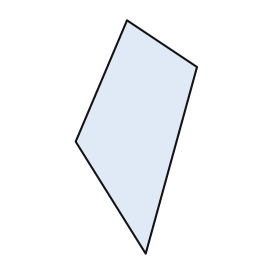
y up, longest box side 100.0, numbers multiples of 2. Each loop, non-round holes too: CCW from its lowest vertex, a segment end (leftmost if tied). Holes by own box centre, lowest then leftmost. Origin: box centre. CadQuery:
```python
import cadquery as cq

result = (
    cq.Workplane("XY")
    .moveTo(4.0, -50.0)
    .lineTo(26.0, 30.0)
    .lineTo(-4.0, 50.0)
    .lineTo(-26.0, -2.0)
    .close()
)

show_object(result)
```